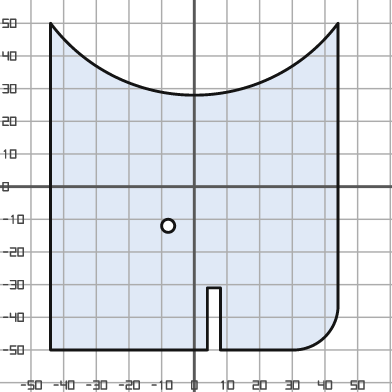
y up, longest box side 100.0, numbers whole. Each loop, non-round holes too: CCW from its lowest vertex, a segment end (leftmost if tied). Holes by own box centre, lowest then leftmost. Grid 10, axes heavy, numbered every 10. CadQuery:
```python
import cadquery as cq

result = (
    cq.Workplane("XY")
    .moveTo(-44.0, -50.0)
    .lineTo(4.0, -50.0)
    .lineTo(4.0, -31.0)
    .lineTo(8.0, -31.0)
    .lineTo(8.0, -50.0)
    .lineTo(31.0, -50.0)
    .threePointArc((40.0, -46.0), (44.0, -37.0))
    .lineTo(44.0, 50.0)
    .threePointArc((0.0, 28.0), (-44.0, 50.0))
    .close()
    .moveTo(-8.0, -12.0)
    .circle(2.0)
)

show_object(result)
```